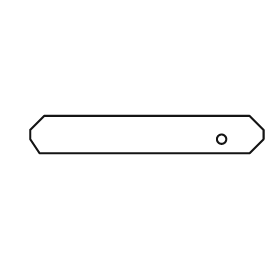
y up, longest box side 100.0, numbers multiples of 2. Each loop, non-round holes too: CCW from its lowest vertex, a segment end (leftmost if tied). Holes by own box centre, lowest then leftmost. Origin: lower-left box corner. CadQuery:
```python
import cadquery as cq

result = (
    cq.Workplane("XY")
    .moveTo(4.0, 0.0)
    .lineTo(94.0, 0.0)
    .lineTo(100.0, 6.0)
    .lineTo(100.0, 10.0)
    .lineTo(94.0, 16.0)
    .lineTo(6.0, 16.0)
    .lineTo(0.0, 10.0)
    .lineTo(0.0, 6.0)
    .close()
    .moveTo(82.0, 6.0)
    .circle(2.0)
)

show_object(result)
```